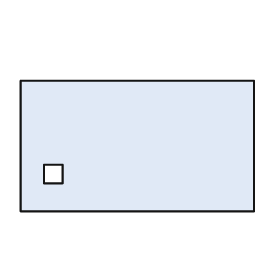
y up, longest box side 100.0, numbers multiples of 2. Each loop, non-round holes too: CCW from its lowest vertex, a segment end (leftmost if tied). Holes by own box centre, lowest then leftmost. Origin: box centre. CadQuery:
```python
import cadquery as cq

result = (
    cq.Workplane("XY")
    .moveTo(-50.0, -28.0)
    .lineTo(50.0, -28.0)
    .lineTo(50.0, 28.0)
    .lineTo(-50.0, 28.0)
    .close()
    .moveTo(-40.0, -16.0)
    .lineTo(-32.0, -16.0)
    .lineTo(-32.0, -8.0)
    .lineTo(-40.0, -8.0)
    .close()
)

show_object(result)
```